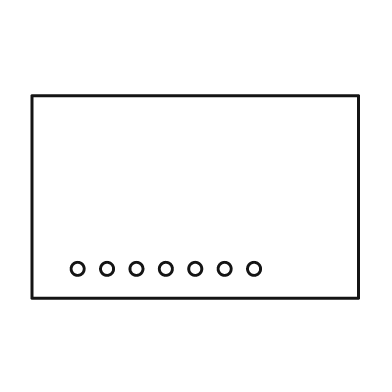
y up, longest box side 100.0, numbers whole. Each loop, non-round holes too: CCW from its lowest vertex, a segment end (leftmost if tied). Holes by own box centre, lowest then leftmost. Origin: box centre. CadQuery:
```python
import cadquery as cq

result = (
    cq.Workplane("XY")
    .moveTo(-50.0, -31.0)
    .lineTo(50.0, -31.0)
    .lineTo(50.0, 31.0)
    .lineTo(-50.0, 31.0)
    .close()
    .moveTo(-36.0, -22.0)
    .circle(2.0)
    .moveTo(-27.0, -22.0)
    .circle(2.0)
    .moveTo(-18.0, -22.0)
    .circle(2.0)
    .moveTo(-9.0, -22.0)
    .circle(2.0)
    .moveTo(0.0, -22.0)
    .circle(2.0)
    .moveTo(9.0, -22.0)
    .circle(2.0)
    .moveTo(18.0, -22.0)
    .circle(2.0)
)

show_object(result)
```